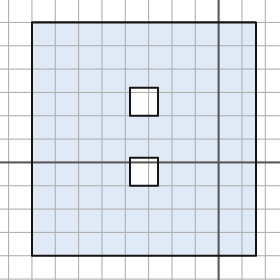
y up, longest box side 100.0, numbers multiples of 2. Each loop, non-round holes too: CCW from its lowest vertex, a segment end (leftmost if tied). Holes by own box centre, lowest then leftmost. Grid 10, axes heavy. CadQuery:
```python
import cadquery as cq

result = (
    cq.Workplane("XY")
    .moveTo(-80.0, -40.0)
    .lineTo(16.0, -40.0)
    .lineTo(16.0, 60.0)
    .lineTo(-80.0, 60.0)
    .close()
    .moveTo(-38.0, -10.0)
    .lineTo(-26.0, -10.0)
    .lineTo(-26.0, 2.0)
    .lineTo(-38.0, 2.0)
    .close()
    .moveTo(-38.0, 20.0)
    .lineTo(-26.0, 20.0)
    .lineTo(-26.0, 32.0)
    .lineTo(-38.0, 32.0)
    .close()
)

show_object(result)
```